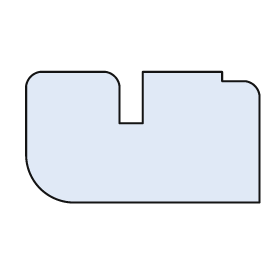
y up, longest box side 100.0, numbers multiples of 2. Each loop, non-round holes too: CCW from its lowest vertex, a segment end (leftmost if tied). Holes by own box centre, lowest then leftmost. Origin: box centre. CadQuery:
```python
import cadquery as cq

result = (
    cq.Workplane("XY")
    .moveTo(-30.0, -28.0)
    .lineTo(50.0, -28.0)
    .lineTo(50.0, 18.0)
    .threePointArc((48.0, 22.0), (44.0, 24.0))
    .lineTo(34.0, 24.0)
    .lineTo(34.0, 28.0)
    .lineTo(0.0, 28.0)
    .lineTo(0.0, 6.0)
    .lineTo(-10.0, 6.0)
    .lineTo(-10.0, 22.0)
    .threePointArc((-12.0, 26.0), (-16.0, 28.0))
    .lineTo(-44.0, 28.0)
    .threePointArc((-48.0, 26.0), (-50.0, 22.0))
    .lineTo(-50.0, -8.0)
    .threePointArc((-44.0, -22.0), (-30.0, -28.0))
    .close()
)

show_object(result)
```